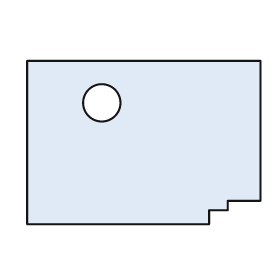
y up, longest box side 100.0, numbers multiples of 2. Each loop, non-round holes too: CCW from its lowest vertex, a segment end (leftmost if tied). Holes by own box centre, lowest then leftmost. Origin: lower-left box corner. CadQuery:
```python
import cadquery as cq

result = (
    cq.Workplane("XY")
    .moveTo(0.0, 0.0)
    .lineTo(78.0, 0.0)
    .lineTo(78.0, 6.0)
    .lineTo(86.0, 6.0)
    .lineTo(86.0, 10.0)
    .lineTo(100.0, 10.0)
    .lineTo(100.0, 70.0)
    .lineTo(0.0, 70.0)
    .close()
    .moveTo(32.0, 52.0)
    .circle(8.0)
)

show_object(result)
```